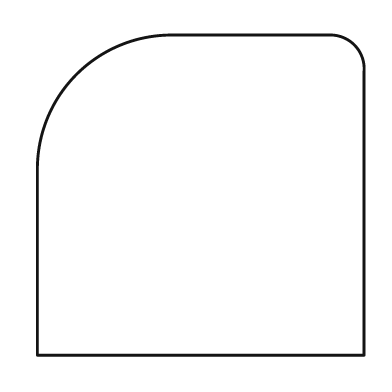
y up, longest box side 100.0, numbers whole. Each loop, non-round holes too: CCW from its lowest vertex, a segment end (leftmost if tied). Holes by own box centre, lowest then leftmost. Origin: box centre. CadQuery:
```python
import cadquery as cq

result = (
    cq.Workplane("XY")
    .moveTo(-50.0, -49.0)
    .lineTo(50.0, -49.0)
    .lineTo(50.0, 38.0)
    .threePointArc((47.0, 46.0), (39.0, 49.0))
    .lineTo(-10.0, 49.0)
    .threePointArc((-38.0, 37.0), (-50.0, 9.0))
    .close()
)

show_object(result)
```